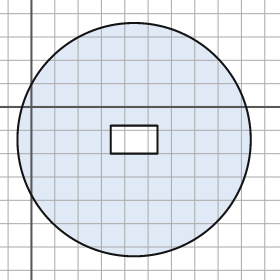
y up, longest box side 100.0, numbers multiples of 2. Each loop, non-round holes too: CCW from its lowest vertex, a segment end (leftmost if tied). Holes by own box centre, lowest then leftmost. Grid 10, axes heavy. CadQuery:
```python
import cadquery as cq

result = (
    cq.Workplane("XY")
    .moveTo(44.0, -14.0)
    .circle(50.0)
    .moveTo(34.0, -20.0)
    .lineTo(54.0, -20.0)
    .lineTo(54.0, -8.0)
    .lineTo(34.0, -8.0)
    .close()
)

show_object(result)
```